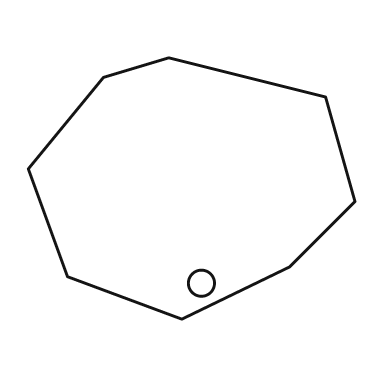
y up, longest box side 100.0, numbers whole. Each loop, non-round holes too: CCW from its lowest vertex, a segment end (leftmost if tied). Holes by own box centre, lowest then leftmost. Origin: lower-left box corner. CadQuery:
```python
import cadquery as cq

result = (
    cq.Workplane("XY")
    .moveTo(47.0, 0.0)
    .lineTo(80.0, 16.0)
    .lineTo(100.0, 36.0)
    .lineTo(91.0, 68.0)
    .lineTo(43.0, 80.0)
    .lineTo(23.0, 74.0)
    .lineTo(0.0, 46.0)
    .lineTo(12.0, 13.0)
    .close()
    .moveTo(53.0, 11.0)
    .circle(4.0)
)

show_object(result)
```